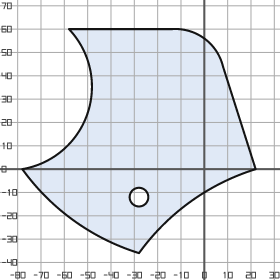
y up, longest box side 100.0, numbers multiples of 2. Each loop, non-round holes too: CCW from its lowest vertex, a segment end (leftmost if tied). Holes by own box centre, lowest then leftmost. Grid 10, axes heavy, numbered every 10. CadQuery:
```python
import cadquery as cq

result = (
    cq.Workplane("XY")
    .moveTo(-28.0, -36.0)
    .threePointArc((-6.0, -14.0), (22.0, 0.0))
    .lineTo(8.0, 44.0)
    .threePointArc((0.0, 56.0), (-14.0, 60.0))
    .lineTo(-58.0, 60.0)
    .threePointArc((-50.0, 24.0), (-78.0, 0.0))
    .threePointArc((-56.0, -22.0), (-28.0, -36.0))
    .close()
    .moveTo(-28.0, -12.0)
    .circle(4.0)
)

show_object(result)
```